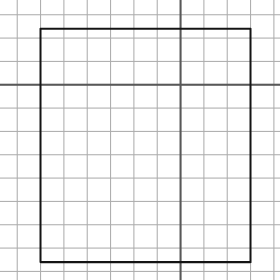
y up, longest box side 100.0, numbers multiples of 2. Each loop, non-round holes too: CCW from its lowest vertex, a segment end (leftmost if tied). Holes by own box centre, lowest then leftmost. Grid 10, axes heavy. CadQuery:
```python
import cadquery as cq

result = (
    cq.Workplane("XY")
    .moveTo(-60.0, -76.0)
    .lineTo(30.0, -76.0)
    .lineTo(30.0, 24.0)
    .lineTo(-60.0, 24.0)
    .close()
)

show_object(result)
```